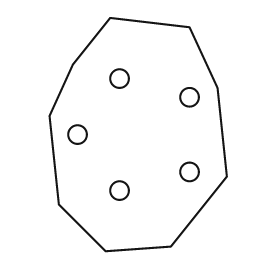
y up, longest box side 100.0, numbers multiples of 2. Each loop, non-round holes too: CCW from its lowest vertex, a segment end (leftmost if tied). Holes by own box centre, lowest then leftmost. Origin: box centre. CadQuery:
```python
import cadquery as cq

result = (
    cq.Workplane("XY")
    .moveTo(-14.0, -50.0)
    .lineTo(14.0, -48.0)
    .lineTo(38.0, -18.0)
    .lineTo(34.0, 20.0)
    .lineTo(22.0, 46.0)
    .lineTo(-12.0, 50.0)
    .lineTo(-28.0, 30.0)
    .lineTo(-38.0, 8.0)
    .lineTo(-34.0, -30.0)
    .close()
    .moveTo(-8.0, -24.0)
    .circle(4.0)
    .moveTo(22.0, -16.0)
    .circle(4.0)
    .moveTo(-26.0, 0.0)
    .circle(4.0)
    .moveTo(22.0, 16.0)
    .circle(4.0)
    .moveTo(-8.0, 24.0)
    .circle(4.0)
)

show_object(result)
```